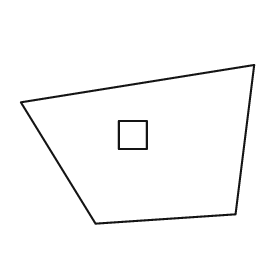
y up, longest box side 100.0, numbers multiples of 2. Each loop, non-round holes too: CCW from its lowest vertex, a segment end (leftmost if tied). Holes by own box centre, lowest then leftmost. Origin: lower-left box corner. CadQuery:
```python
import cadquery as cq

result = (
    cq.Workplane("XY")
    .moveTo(32.0, 0.0)
    .lineTo(92.0, 4.0)
    .lineTo(100.0, 68.0)
    .lineTo(0.0, 52.0)
    .close()
    .moveTo(42.0, 32.0)
    .lineTo(54.0, 32.0)
    .lineTo(54.0, 44.0)
    .lineTo(42.0, 44.0)
    .close()
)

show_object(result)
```